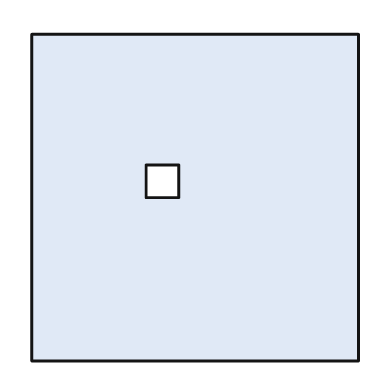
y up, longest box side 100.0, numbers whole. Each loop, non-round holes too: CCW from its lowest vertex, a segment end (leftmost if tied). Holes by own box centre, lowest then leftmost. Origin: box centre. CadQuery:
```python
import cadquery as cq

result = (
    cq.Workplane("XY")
    .moveTo(-50.0, -50.0)
    .lineTo(50.0, -50.0)
    .lineTo(50.0, 50.0)
    .lineTo(-50.0, 50.0)
    .close()
    .moveTo(-15.0, 0.0)
    .lineTo(-5.0, 0.0)
    .lineTo(-5.0, 10.0)
    .lineTo(-15.0, 10.0)
    .close()
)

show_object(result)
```